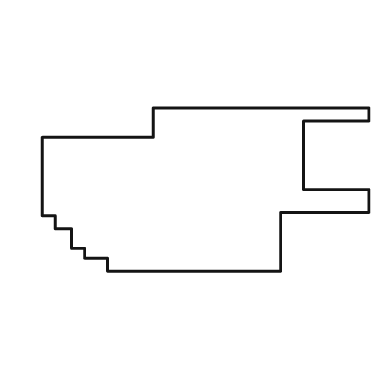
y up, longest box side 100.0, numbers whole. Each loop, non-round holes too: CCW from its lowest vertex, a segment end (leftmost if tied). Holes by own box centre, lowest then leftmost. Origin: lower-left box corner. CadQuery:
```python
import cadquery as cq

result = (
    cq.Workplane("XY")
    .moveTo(20.0, 0.0)
    .lineTo(73.0, 0.0)
    .lineTo(73.0, 18.0)
    .lineTo(100.0, 18.0)
    .lineTo(100.0, 25.0)
    .lineTo(80.0, 25.0)
    .lineTo(80.0, 46.0)
    .lineTo(100.0, 46.0)
    .lineTo(100.0, 50.0)
    .lineTo(34.0, 50.0)
    .lineTo(34.0, 41.0)
    .lineTo(0.0, 41.0)
    .lineTo(0.0, 17.0)
    .lineTo(4.0, 17.0)
    .lineTo(4.0, 13.0)
    .lineTo(9.0, 13.0)
    .lineTo(9.0, 7.0)
    .lineTo(13.0, 7.0)
    .lineTo(13.0, 4.0)
    .lineTo(20.0, 4.0)
    .close()
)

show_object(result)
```